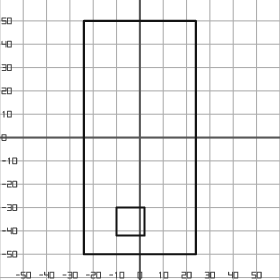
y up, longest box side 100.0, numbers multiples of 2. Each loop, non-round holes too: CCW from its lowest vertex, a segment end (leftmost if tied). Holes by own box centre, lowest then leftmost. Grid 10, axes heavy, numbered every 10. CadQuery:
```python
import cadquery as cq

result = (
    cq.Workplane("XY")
    .moveTo(-24.0, -50.0)
    .lineTo(24.0, -50.0)
    .lineTo(24.0, 50.0)
    .lineTo(-24.0, 50.0)
    .close()
    .moveTo(-10.0, -42.0)
    .lineTo(2.0, -42.0)
    .lineTo(2.0, -30.0)
    .lineTo(-10.0, -30.0)
    .close()
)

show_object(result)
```